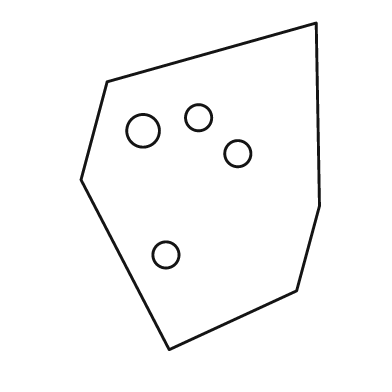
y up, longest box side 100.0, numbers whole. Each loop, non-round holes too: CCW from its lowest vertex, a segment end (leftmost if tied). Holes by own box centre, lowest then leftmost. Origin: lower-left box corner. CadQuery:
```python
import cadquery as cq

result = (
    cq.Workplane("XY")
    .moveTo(27.0, 0.0)
    .lineTo(66.0, 18.0)
    .lineTo(73.0, 44.0)
    .lineTo(72.0, 100.0)
    .lineTo(8.0, 82.0)
    .lineTo(0.0, 52.0)
    .close()
    .moveTo(26.0, 29.0)
    .circle(4.0)
    .moveTo(48.0, 60.0)
    .circle(4.0)
    .moveTo(19.0, 67.0)
    .circle(5.0)
    .moveTo(36.0, 71.0)
    .circle(4.0)
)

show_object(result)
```